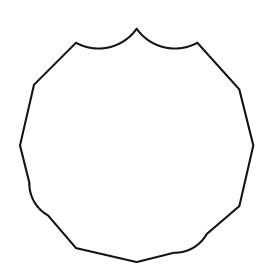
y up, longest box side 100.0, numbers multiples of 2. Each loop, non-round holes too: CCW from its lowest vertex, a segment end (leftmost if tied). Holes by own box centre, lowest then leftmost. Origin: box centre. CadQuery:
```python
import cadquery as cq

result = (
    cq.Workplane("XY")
    .moveTo(0.0, -50.0)
    .lineTo(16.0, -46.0)
    .threePointArc((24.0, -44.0), (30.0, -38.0))
    .lineTo(44.0, -26.0)
    .lineTo(50.0, 0.0)
    .lineTo(44.0, 24.0)
    .lineTo(26.0, 44.0)
    .threePointArc((12.0, 42.0), (0.0, 50.0))
    .threePointArc((-12.0, 42.0), (-26.0, 44.0))
    .lineTo(-44.0, 26.0)
    .lineTo(-50.0, 0.0)
    .lineTo(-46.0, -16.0)
    .threePointArc((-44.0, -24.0), (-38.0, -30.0))
    .lineTo(-26.0, -44.0)
    .close()
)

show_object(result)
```